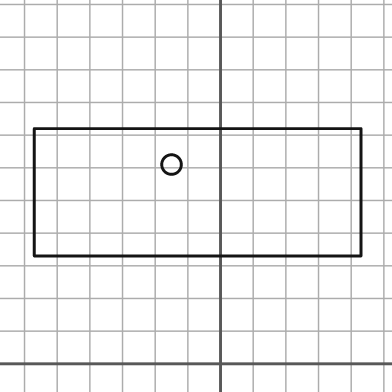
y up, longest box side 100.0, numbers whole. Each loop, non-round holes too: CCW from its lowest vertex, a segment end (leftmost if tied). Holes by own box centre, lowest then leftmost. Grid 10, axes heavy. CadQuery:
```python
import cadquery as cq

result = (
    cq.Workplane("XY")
    .moveTo(-57.0, 33.0)
    .lineTo(43.0, 33.0)
    .lineTo(43.0, 72.0)
    .lineTo(-57.0, 72.0)
    .close()
    .moveTo(-15.0, 61.0)
    .circle(3.0)
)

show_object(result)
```